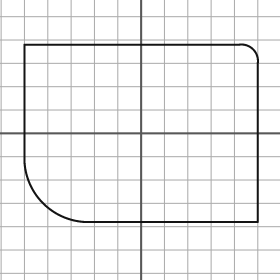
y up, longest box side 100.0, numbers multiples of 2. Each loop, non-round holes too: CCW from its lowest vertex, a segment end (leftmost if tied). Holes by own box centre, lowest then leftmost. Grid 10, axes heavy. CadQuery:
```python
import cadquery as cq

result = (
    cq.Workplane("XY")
    .moveTo(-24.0, -38.0)
    .lineTo(50.0, -38.0)
    .lineTo(50.0, 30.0)
    .threePointArc((48.0, 36.0), (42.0, 38.0))
    .lineTo(-50.0, 38.0)
    .lineTo(-50.0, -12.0)
    .threePointArc((-42.0, -30.0), (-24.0, -38.0))
    .close()
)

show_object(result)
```